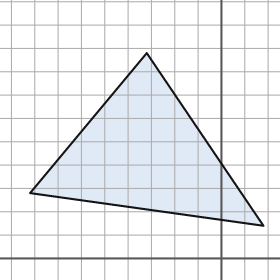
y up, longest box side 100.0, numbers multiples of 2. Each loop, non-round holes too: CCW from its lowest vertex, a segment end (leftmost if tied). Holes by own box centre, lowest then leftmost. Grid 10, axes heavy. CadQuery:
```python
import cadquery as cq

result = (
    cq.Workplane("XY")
    .moveTo(18.0, 14.0)
    .lineTo(-32.0, 88.0)
    .lineTo(-82.0, 28.0)
    .close()
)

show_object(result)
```